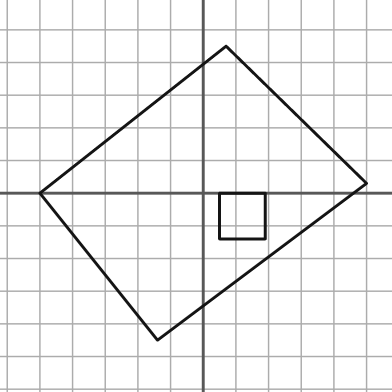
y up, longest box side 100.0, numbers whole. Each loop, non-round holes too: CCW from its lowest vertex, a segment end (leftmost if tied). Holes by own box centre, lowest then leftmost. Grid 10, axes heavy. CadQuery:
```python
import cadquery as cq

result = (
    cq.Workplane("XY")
    .moveTo(-14.0, -45.0)
    .lineTo(50.0, 3.0)
    .lineTo(7.0, 45.0)
    .lineTo(-50.0, 0.0)
    .close()
    .moveTo(5.0, -14.0)
    .lineTo(19.0, -14.0)
    .lineTo(19.0, 0.0)
    .lineTo(5.0, 0.0)
    .close()
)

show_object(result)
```